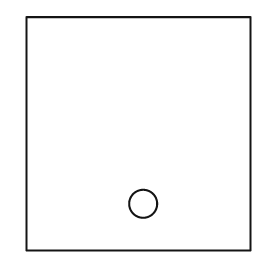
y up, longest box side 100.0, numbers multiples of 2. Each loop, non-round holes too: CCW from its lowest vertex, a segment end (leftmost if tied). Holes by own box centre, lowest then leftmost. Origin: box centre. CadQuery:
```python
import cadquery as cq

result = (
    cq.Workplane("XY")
    .moveTo(-48.0, -50.0)
    .lineTo(48.0, -50.0)
    .lineTo(48.0, 50.0)
    .lineTo(-48.0, 50.0)
    .close()
    .moveTo(2.0, -30.0)
    .circle(6.0)
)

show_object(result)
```